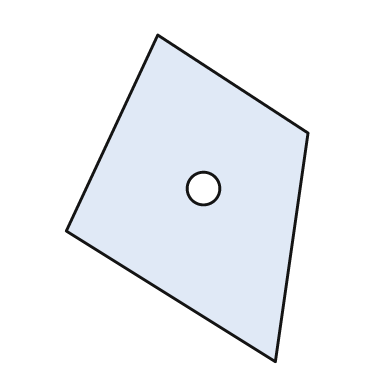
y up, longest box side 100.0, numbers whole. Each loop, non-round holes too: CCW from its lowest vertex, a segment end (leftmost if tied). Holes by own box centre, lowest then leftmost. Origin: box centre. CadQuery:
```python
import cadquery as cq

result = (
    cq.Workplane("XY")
    .moveTo(27.0, -50.0)
    .lineTo(37.0, 20.0)
    .lineTo(-9.0, 50.0)
    .lineTo(-37.0, -10.0)
    .close()
    .moveTo(5.0, 3.0)
    .circle(5.0)
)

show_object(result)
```